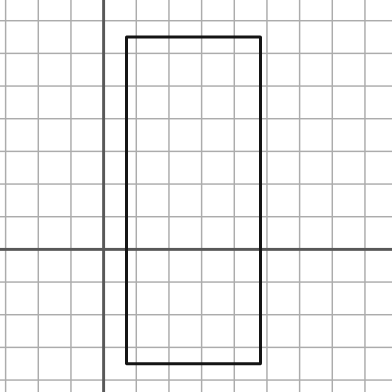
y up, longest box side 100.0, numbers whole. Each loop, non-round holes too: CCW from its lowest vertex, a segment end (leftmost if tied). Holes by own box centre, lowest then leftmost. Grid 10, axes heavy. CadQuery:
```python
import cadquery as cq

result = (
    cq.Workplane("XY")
    .moveTo(7.0, -35.0)
    .lineTo(48.0, -35.0)
    .lineTo(48.0, 65.0)
    .lineTo(7.0, 65.0)
    .close()
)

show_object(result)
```